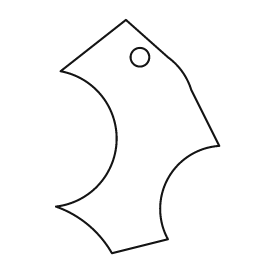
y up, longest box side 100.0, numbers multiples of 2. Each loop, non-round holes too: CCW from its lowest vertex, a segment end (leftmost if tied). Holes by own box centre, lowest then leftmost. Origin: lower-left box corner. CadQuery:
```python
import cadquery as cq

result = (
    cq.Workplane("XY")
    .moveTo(24.0, 0.0)
    .lineTo(48.0, 6.0)
    .threePointArc((48.0, 32.0), (70.0, 46.0))
    .lineTo(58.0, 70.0)
    .threePointArc((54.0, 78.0), (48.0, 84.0))
    .lineTo(30.0, 100.0)
    .lineTo(2.0, 78.0)
    .threePointArc((26.0, 48.0), (0.0, 20.0))
    .threePointArc((14.0, 12.0), (24.0, 0.0))
    .close()
    .moveTo(36.0, 84.0)
    .circle(4.0)
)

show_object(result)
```